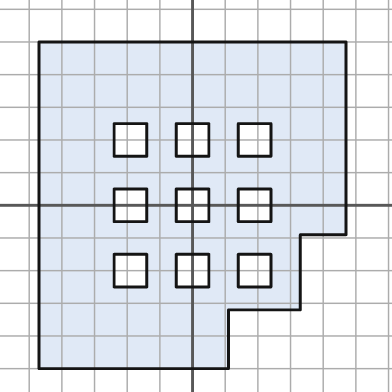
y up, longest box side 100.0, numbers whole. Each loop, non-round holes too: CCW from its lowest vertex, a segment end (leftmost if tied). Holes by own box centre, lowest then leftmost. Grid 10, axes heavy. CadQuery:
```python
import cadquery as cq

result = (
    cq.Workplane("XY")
    .moveTo(-47.0, -50.0)
    .lineTo(11.0, -50.0)
    .lineTo(11.0, -32.0)
    .lineTo(33.0, -32.0)
    .lineTo(33.0, -9.0)
    .lineTo(47.0, -9.0)
    .lineTo(47.0, 50.0)
    .lineTo(-47.0, 50.0)
    .close()
    .moveTo(-24.0, -25.0)
    .lineTo(-14.0, -25.0)
    .lineTo(-14.0, -15.0)
    .lineTo(-24.0, -15.0)
    .close()
    .moveTo(-5.0, -25.0)
    .lineTo(5.0, -25.0)
    .lineTo(5.0, -15.0)
    .lineTo(-5.0, -15.0)
    .close()
    .moveTo(14.0, -25.0)
    .lineTo(24.0, -25.0)
    .lineTo(24.0, -15.0)
    .lineTo(14.0, -15.0)
    .close()
    .moveTo(-24.0, -5.0)
    .lineTo(-14.0, -5.0)
    .lineTo(-14.0, 5.0)
    .lineTo(-24.0, 5.0)
    .close()
    .moveTo(-5.0, -5.0)
    .lineTo(5.0, -5.0)
    .lineTo(5.0, 5.0)
    .lineTo(-5.0, 5.0)
    .close()
    .moveTo(14.0, -5.0)
    .lineTo(24.0, -5.0)
    .lineTo(24.0, 5.0)
    .lineTo(14.0, 5.0)
    .close()
    .moveTo(-24.0, 15.0)
    .lineTo(-14.0, 15.0)
    .lineTo(-14.0, 25.0)
    .lineTo(-24.0, 25.0)
    .close()
    .moveTo(-5.0, 15.0)
    .lineTo(5.0, 15.0)
    .lineTo(5.0, 25.0)
    .lineTo(-5.0, 25.0)
    .close()
    .moveTo(14.0, 15.0)
    .lineTo(24.0, 15.0)
    .lineTo(24.0, 25.0)
    .lineTo(14.0, 25.0)
    .close()
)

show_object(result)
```